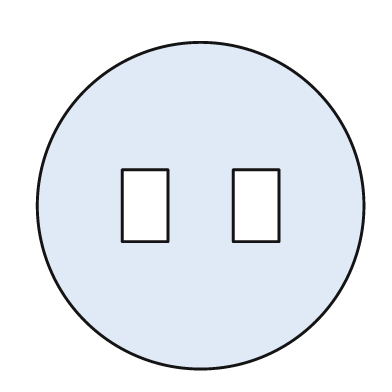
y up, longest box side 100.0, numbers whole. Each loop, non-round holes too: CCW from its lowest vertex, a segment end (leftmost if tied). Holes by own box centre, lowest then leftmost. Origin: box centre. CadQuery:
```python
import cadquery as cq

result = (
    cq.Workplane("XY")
    .moveTo(0.0, 0.0)
    .circle(50.0)
    .moveTo(-24.0, -11.0)
    .lineTo(-10.0, -11.0)
    .lineTo(-10.0, 11.0)
    .lineTo(-24.0, 11.0)
    .close()
    .moveTo(10.0, -11.0)
    .lineTo(24.0, -11.0)
    .lineTo(24.0, 11.0)
    .lineTo(10.0, 11.0)
    .close()
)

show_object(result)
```